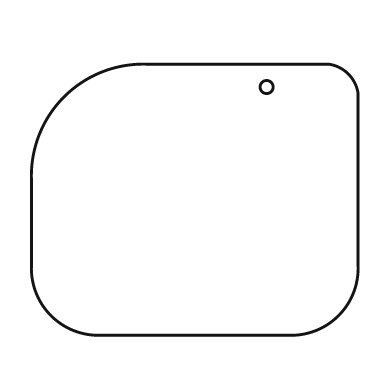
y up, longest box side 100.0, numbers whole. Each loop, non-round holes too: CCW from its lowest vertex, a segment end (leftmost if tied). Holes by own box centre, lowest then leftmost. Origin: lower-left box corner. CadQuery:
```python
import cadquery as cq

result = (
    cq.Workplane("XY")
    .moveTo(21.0, 0.0)
    .lineTo(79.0, 0.0)
    .threePointArc((94.0, 6.0), (100.0, 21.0))
    .lineTo(100.0, 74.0)
    .threePointArc((97.0, 80.0), (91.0, 83.0))
    .lineTo(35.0, 83.0)
    .threePointArc((10.0, 73.0), (0.0, 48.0))
    .lineTo(0.0, 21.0)
    .threePointArc((6.0, 6.0), (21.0, 0.0))
    .close()
    .moveTo(72.0, 76.0)
    .circle(2.0)
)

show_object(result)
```